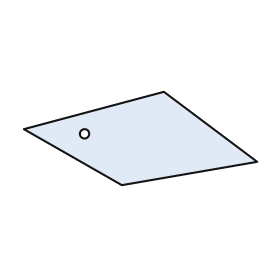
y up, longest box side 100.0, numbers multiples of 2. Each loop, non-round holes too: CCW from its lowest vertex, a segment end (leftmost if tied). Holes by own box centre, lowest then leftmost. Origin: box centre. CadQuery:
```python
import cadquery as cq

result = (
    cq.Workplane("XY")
    .moveTo(-8.0, -20.0)
    .lineTo(50.0, -10.0)
    .lineTo(10.0, 20.0)
    .lineTo(-50.0, 4.0)
    .close()
    .moveTo(-24.0, 2.0)
    .circle(2.0)
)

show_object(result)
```